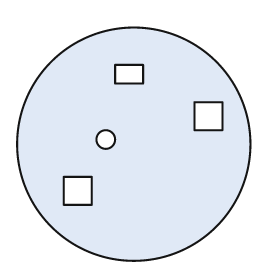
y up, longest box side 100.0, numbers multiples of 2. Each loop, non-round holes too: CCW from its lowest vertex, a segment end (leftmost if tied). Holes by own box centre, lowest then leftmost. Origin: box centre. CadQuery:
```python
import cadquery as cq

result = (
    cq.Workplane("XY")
    .moveTo(0.0, 0.0)
    .circle(50.0)
    .moveTo(-30.0, -26.0)
    .lineTo(-18.0, -26.0)
    .lineTo(-18.0, -14.0)
    .lineTo(-30.0, -14.0)
    .close()
    .moveTo(-12.0, 2.0)
    .circle(4.0)
    .moveTo(26.0, 6.0)
    .lineTo(38.0, 6.0)
    .lineTo(38.0, 18.0)
    .lineTo(26.0, 18.0)
    .close()
    .moveTo(-8.0, 26.0)
    .lineTo(4.0, 26.0)
    .lineTo(4.0, 34.0)
    .lineTo(-8.0, 34.0)
    .close()
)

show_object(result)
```